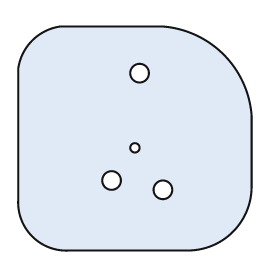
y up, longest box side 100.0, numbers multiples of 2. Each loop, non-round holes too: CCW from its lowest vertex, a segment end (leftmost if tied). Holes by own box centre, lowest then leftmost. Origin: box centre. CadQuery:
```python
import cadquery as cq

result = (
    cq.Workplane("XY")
    .moveTo(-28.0, -48.0)
    .lineTo(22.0, -48.0)
    .threePointArc((42.0, -40.0), (50.0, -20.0))
    .lineTo(50.0, 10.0)
    .threePointArc((38.0, 36.0), (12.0, 48.0))
    .lineTo(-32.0, 48.0)
    .threePointArc((-44.0, 42.0), (-50.0, 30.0))
    .lineTo(-50.0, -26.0)
    .threePointArc((-44.0, -42.0), (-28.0, -48.0))
    .close()
    .moveTo(12.0, -22.0)
    .circle(4.0)
    .moveTo(-10.0, -18.0)
    .circle(4.0)
    .moveTo(0.0, -4.0)
    .circle(2.0)
    .moveTo(2.0, 28.0)
    .circle(4.0)
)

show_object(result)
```